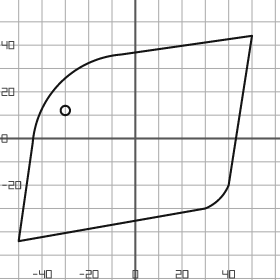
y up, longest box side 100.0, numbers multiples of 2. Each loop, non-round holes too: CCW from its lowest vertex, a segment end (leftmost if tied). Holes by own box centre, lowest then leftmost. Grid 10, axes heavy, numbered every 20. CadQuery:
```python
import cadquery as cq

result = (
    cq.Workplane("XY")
    .moveTo(-50.0, -44.0)
    .lineTo(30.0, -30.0)
    .threePointArc((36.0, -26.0), (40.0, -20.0))
    .lineTo(50.0, 44.0)
    .lineTo(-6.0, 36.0)
    .threePointArc((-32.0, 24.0), (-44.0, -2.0))
    .close()
    .moveTo(-30.0, 12.0)
    .circle(2.0)
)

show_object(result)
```